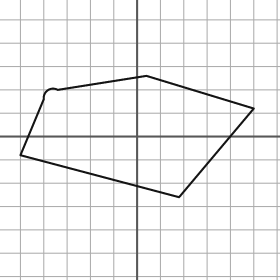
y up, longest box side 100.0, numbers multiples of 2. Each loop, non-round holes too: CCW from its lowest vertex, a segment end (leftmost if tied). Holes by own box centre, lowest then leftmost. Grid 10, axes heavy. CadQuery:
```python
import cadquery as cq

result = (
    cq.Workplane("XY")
    .moveTo(18.0, -26.0)
    .lineTo(50.0, 12.0)
    .lineTo(4.0, 26.0)
    .lineTo(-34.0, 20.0)
    .threePointArc((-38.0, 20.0), (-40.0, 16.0))
    .lineTo(-50.0, -8.0)
    .close()
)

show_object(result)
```